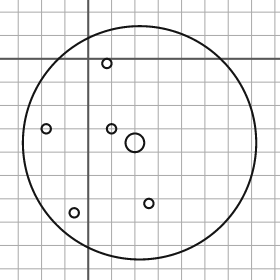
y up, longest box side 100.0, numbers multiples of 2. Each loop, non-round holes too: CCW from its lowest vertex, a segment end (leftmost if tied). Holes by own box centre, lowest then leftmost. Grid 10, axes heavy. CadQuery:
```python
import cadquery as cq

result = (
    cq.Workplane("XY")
    .moveTo(22.0, -36.0)
    .circle(50.0)
    .moveTo(-6.0, -66.0)
    .circle(2.0)
    .moveTo(26.0, -62.0)
    .circle(2.0)
    .moveTo(20.0, -36.0)
    .circle(4.0)
    .moveTo(-18.0, -30.0)
    .circle(2.0)
    .moveTo(10.0, -30.0)
    .circle(2.0)
    .moveTo(8.0, -2.0)
    .circle(2.0)
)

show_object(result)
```